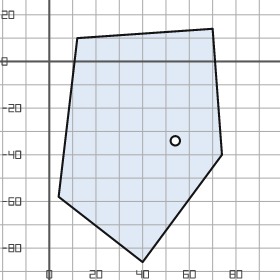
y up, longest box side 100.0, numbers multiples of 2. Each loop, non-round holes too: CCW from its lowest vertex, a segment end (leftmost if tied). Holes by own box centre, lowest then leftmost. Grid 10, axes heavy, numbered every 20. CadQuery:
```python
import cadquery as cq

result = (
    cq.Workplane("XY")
    .moveTo(40.0, -86.0)
    .lineTo(74.0, -40.0)
    .lineTo(70.0, 14.0)
    .lineTo(12.0, 10.0)
    .lineTo(4.0, -58.0)
    .close()
    .moveTo(54.0, -34.0)
    .circle(2.0)
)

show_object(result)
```